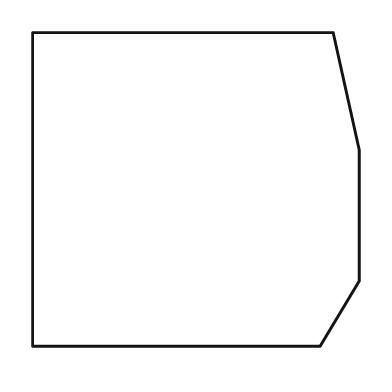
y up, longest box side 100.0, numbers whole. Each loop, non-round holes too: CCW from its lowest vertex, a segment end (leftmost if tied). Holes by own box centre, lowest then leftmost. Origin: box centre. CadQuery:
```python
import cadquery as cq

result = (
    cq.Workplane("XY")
    .moveTo(-50.0, -48.0)
    .lineTo(38.0, -48.0)
    .lineTo(50.0, -28.0)
    .lineTo(50.0, 12.0)
    .lineTo(42.0, 48.0)
    .lineTo(-50.0, 48.0)
    .close()
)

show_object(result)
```